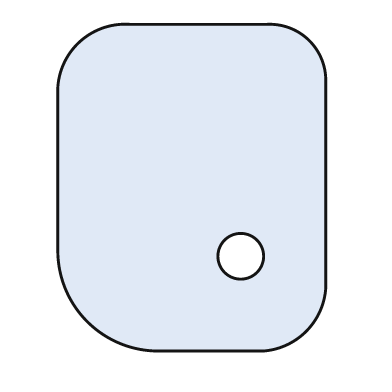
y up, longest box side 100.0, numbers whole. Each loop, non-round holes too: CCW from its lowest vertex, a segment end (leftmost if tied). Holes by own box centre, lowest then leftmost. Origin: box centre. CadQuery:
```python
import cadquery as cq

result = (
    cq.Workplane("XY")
    .moveTo(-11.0, -50.0)
    .lineTo(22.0, -50.0)
    .threePointArc((35.0, -44.0), (41.0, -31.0))
    .lineTo(41.0, 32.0)
    .threePointArc((36.0, 45.0), (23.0, 50.0))
    .lineTo(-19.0, 50.0)
    .threePointArc((-35.0, 44.0), (-41.0, 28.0))
    .lineTo(-41.0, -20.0)
    .threePointArc((-32.0, -41.0), (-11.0, -50.0))
    .close()
    .moveTo(15.0, -21.0)
    .circle(7.0)
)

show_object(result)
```